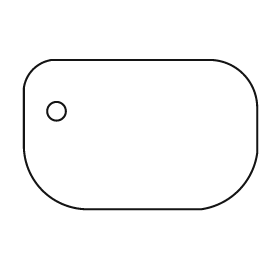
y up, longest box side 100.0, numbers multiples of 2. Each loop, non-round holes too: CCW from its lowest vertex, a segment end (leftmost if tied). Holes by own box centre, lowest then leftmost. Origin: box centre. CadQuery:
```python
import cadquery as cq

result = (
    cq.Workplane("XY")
    .moveTo(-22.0, -32.0)
    .lineTo(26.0, -32.0)
    .threePointArc((42.0, -24.0), (50.0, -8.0))
    .lineTo(50.0, 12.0)
    .threePointArc((44.0, 26.0), (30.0, 32.0))
    .lineTo(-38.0, 32.0)
    .threePointArc((-46.0, 28.0), (-50.0, 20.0))
    .lineTo(-50.0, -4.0)
    .threePointArc((-42.0, -24.0), (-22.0, -32.0))
    .close()
    .moveTo(-36.0, 10.0)
    .circle(4.0)
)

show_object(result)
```